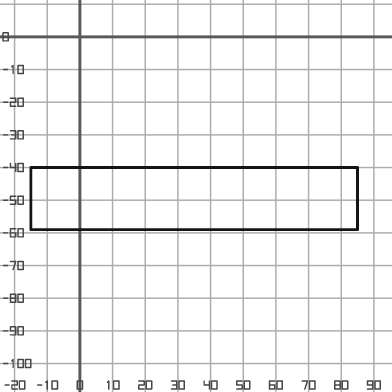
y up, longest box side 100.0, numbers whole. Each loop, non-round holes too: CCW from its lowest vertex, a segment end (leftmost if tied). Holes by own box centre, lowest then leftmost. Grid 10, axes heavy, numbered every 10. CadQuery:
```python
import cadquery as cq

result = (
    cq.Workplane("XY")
    .moveTo(-15.0, -59.0)
    .lineTo(85.0, -59.0)
    .lineTo(85.0, -40.0)
    .lineTo(-15.0, -40.0)
    .close()
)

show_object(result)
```